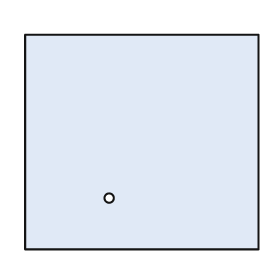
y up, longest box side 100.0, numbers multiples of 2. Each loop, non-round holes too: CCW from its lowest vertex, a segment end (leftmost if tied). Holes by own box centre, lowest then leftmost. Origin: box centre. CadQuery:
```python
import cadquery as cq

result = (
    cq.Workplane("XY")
    .moveTo(-50.0, -46.0)
    .lineTo(50.0, -46.0)
    .lineTo(50.0, 46.0)
    .lineTo(-50.0, 46.0)
    .close()
    .moveTo(-14.0, -24.0)
    .circle(2.0)
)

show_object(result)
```